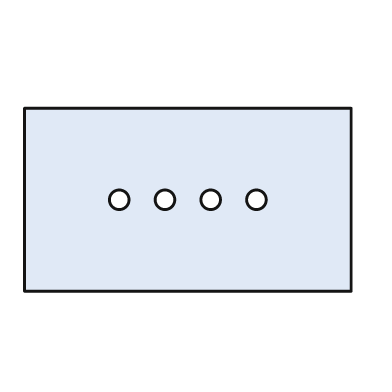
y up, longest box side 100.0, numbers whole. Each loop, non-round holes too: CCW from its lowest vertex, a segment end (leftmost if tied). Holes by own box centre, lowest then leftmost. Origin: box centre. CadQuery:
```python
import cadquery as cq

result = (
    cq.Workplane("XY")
    .moveTo(-50.0, -28.0)
    .lineTo(50.0, -28.0)
    .lineTo(50.0, 28.0)
    .lineTo(-50.0, 28.0)
    .close()
    .moveTo(-21.0, 0.0)
    .circle(3.0)
    .moveTo(-7.0, 0.0)
    .circle(3.0)
    .moveTo(7.0, 0.0)
    .circle(3.0)
    .moveTo(21.0, 0.0)
    .circle(3.0)
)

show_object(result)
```